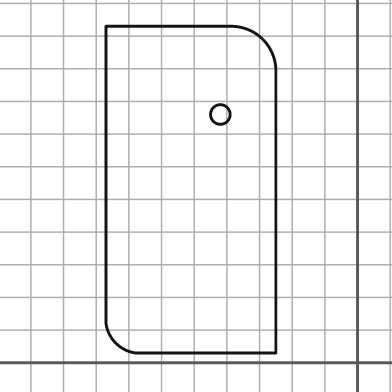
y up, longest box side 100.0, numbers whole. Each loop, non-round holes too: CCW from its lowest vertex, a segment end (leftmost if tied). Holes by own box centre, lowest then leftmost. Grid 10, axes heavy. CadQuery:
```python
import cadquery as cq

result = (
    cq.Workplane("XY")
    .moveTo(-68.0, 3.0)
    .lineTo(-25.0, 3.0)
    .lineTo(-25.0, 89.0)
    .threePointArc((-29.0, 99.0), (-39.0, 103.0))
    .lineTo(-77.0, 103.0)
    .lineTo(-77.0, 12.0)
    .threePointArc((-74.0, 6.0), (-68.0, 3.0))
    .close()
    .moveTo(-42.0, 76.0)
    .circle(3.0)
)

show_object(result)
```